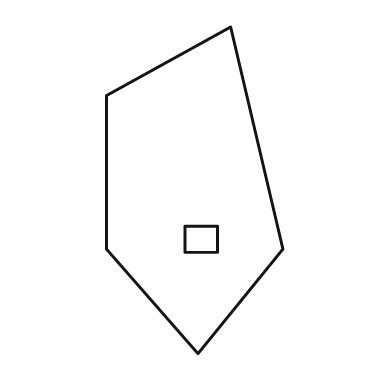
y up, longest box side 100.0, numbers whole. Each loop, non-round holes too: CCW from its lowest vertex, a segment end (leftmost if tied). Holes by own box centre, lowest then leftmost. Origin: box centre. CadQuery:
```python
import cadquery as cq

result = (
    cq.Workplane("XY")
    .moveTo(1.0, -50.0)
    .lineTo(27.0, -18.0)
    .lineTo(11.0, 50.0)
    .lineTo(-27.0, 29.0)
    .lineTo(-27.0, -18.0)
    .close()
    .moveTo(-3.0, -19.0)
    .lineTo(7.0, -19.0)
    .lineTo(7.0, -11.0)
    .lineTo(-3.0, -11.0)
    .close()
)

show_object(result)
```